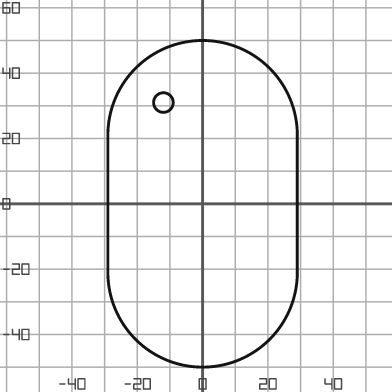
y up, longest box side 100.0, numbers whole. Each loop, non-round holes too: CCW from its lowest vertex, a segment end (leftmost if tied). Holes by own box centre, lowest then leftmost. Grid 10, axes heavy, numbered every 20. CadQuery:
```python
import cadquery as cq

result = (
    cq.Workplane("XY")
    .moveTo(-29.0, -21.0)
    .threePointArc((0.0, -50.0), (29.0, -21.0))
    .lineTo(29.0, 21.0)
    .threePointArc((0.0, 50.0), (-29.0, 21.0))
    .close()
    .moveTo(-12.0, 31.0)
    .circle(3.0)
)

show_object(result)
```